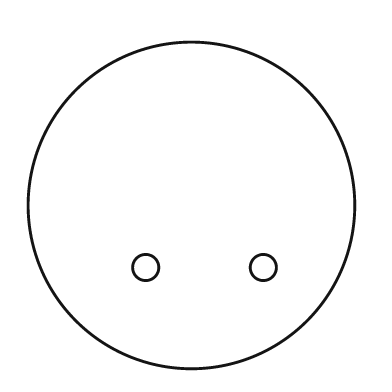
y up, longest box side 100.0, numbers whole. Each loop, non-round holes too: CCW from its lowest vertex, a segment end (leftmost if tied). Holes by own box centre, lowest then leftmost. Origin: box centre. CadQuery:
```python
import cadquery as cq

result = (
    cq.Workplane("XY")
    .moveTo(0.0, 0.0)
    .circle(50.0)
    .moveTo(-14.0, -19.0)
    .circle(4.0)
    .moveTo(22.0, -19.0)
    .circle(4.0)
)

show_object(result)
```